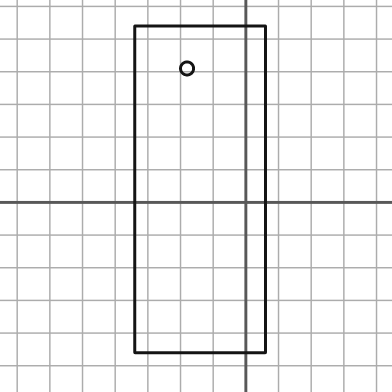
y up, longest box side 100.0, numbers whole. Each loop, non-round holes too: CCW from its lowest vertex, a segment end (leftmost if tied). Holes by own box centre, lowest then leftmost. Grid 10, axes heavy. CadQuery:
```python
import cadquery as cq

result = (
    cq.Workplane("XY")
    .moveTo(-34.0, -46.0)
    .lineTo(6.0, -46.0)
    .lineTo(6.0, 54.0)
    .lineTo(-34.0, 54.0)
    .close()
    .moveTo(-18.0, 41.0)
    .circle(2.0)
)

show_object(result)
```